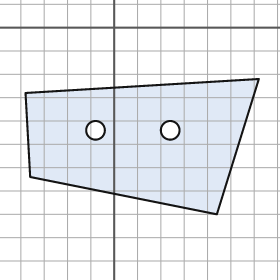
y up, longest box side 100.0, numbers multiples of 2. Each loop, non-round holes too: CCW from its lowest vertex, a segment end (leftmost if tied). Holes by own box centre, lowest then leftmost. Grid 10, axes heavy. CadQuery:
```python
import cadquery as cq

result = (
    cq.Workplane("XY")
    .moveTo(44.0, -80.0)
    .lineTo(62.0, -22.0)
    .lineTo(-38.0, -28.0)
    .lineTo(-36.0, -64.0)
    .close()
    .moveTo(-8.0, -44.0)
    .circle(4.0)
    .moveTo(24.0, -44.0)
    .circle(4.0)
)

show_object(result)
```